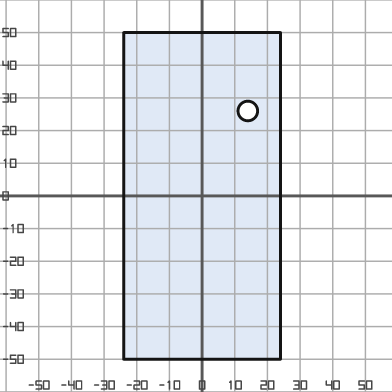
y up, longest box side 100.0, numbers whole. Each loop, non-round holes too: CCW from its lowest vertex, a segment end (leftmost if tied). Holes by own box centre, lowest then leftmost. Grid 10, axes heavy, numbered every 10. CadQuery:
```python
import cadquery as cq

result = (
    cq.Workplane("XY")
    .moveTo(-24.0, -50.0)
    .lineTo(24.0, -50.0)
    .lineTo(24.0, 50.0)
    .lineTo(-24.0, 50.0)
    .close()
    .moveTo(14.0, 26.0)
    .circle(3.0)
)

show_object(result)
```